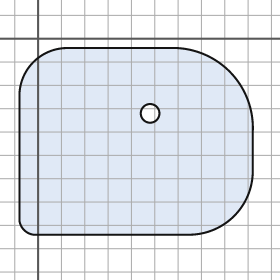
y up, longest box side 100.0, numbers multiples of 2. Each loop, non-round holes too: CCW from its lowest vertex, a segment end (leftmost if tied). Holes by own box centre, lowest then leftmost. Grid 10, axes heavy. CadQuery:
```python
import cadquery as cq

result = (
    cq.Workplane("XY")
    .moveTo(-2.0, -84.0)
    .lineTo(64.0, -84.0)
    .threePointArc((84.0, -76.0), (92.0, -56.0))
    .lineTo(92.0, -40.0)
    .threePointArc((82.0, -14.0), (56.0, -4.0))
    .lineTo(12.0, -4.0)
    .threePointArc((-2.0, -10.0), (-8.0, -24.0))
    .lineTo(-8.0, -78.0)
    .threePointArc((-6.0, -82.0), (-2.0, -84.0))
    .close()
    .moveTo(48.0, -32.0)
    .circle(4.0)
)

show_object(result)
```